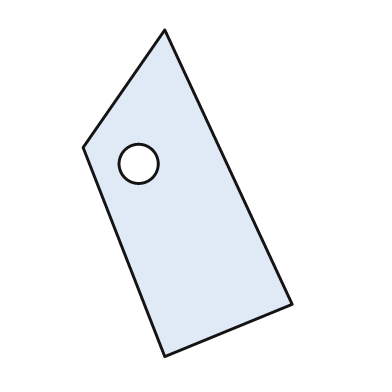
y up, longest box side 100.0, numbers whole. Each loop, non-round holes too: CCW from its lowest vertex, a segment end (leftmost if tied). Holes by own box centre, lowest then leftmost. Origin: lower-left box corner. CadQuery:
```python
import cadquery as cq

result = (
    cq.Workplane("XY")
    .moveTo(25.0, 0.0)
    .lineTo(64.0, 16.0)
    .lineTo(25.0, 100.0)
    .lineTo(0.0, 64.0)
    .close()
    .moveTo(17.0, 59.0)
    .circle(6.0)
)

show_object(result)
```